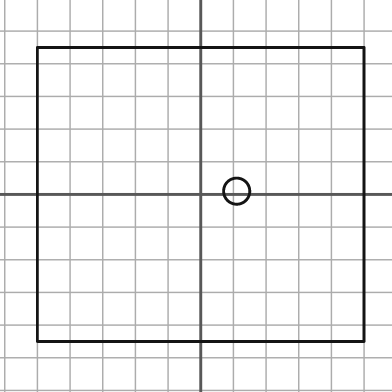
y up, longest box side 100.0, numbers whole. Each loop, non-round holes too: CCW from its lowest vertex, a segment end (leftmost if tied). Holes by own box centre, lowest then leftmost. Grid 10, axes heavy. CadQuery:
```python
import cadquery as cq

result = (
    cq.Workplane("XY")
    .moveTo(-50.0, -45.0)
    .lineTo(50.0, -45.0)
    .lineTo(50.0, 45.0)
    .lineTo(-50.0, 45.0)
    .close()
    .moveTo(11.0, 1.0)
    .circle(4.0)
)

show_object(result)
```